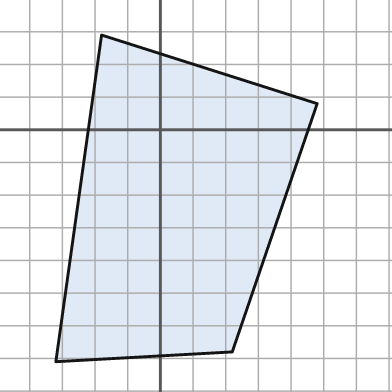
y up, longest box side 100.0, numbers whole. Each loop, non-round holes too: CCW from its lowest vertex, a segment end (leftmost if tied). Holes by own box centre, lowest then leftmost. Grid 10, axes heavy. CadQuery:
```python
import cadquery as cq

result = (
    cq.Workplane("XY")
    .moveTo(-32.0, -71.0)
    .lineTo(22.0, -68.0)
    .lineTo(48.0, 8.0)
    .lineTo(-18.0, 29.0)
    .close()
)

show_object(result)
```